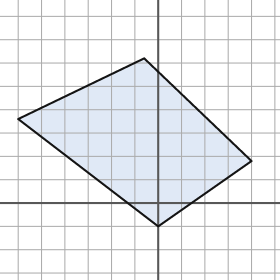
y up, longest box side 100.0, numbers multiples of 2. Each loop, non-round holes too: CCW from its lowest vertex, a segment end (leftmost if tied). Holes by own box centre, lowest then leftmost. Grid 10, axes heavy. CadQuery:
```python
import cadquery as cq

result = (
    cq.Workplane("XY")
    .moveTo(0.0, -10.0)
    .lineTo(40.0, 18.0)
    .lineTo(-6.0, 62.0)
    .lineTo(-60.0, 36.0)
    .close()
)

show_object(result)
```